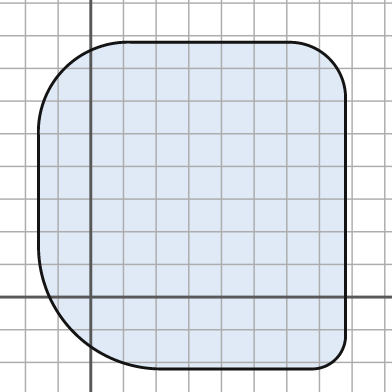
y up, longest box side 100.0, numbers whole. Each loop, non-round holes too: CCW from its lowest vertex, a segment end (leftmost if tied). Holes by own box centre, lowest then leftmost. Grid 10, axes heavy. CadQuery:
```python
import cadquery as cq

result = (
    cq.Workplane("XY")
    .moveTo(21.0, -22.0)
    .lineTo(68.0, -22.0)
    .threePointArc((75.0, -19.0), (78.0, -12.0))
    .lineTo(78.0, 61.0)
    .threePointArc((73.0, 73.0), (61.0, 78.0))
    .lineTo(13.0, 78.0)
    .threePointArc((-8.0, 70.0), (-16.0, 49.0))
    .lineTo(-16.0, 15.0)
    .threePointArc((-5.0, -11.0), (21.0, -22.0))
    .close()
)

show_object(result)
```